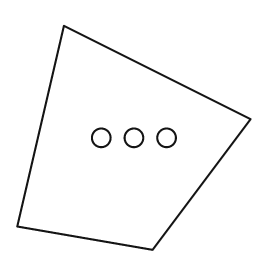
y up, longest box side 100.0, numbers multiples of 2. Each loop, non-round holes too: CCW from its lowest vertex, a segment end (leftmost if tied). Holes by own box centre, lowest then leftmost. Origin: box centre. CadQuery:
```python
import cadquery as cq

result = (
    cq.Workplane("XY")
    .moveTo(8.0, -48.0)
    .lineTo(50.0, 8.0)
    .lineTo(-30.0, 48.0)
    .lineTo(-50.0, -38.0)
    .close()
    .moveTo(-14.0, 0.0)
    .circle(4.0)
    .moveTo(0.0, 0.0)
    .circle(4.0)
    .moveTo(14.0, 0.0)
    .circle(4.0)
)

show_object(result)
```